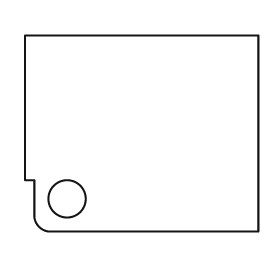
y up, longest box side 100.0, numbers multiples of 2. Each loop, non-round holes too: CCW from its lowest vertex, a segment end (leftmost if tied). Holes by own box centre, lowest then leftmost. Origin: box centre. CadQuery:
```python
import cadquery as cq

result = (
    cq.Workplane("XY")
    .moveTo(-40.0, -42.0)
    .lineTo(50.0, -42.0)
    .lineTo(50.0, 42.0)
    .lineTo(-50.0, 42.0)
    .lineTo(-50.0, -20.0)
    .lineTo(-46.0, -20.0)
    .lineTo(-46.0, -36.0)
    .threePointArc((-44.0, -40.0), (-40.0, -42.0))
    .close()
    .moveTo(-32.0, -28.0)
    .circle(8.0)
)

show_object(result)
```